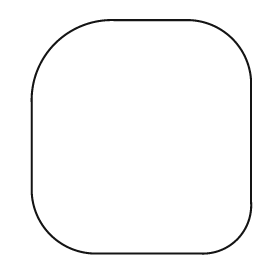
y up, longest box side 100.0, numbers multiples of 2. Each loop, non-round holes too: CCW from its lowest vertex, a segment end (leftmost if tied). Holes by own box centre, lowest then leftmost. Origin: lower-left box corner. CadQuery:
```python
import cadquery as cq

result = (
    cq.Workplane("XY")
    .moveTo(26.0, 0.0)
    .lineTo(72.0, 0.0)
    .threePointArc((88.0, 6.0), (94.0, 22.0))
    .lineTo(94.0, 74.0)
    .threePointArc((86.0, 92.0), (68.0, 100.0))
    .lineTo(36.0, 100.0)
    .threePointArc((10.0, 90.0), (0.0, 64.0))
    .lineTo(0.0, 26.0)
    .threePointArc((8.0, 8.0), (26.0, 0.0))
    .close()
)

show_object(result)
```